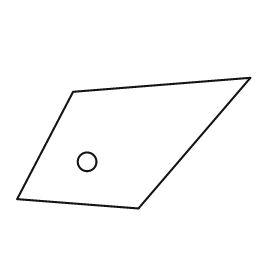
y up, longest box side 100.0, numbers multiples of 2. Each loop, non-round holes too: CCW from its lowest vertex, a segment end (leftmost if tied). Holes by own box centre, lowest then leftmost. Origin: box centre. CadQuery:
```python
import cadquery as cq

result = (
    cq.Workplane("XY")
    .moveTo(2.0, -28.0)
    .lineTo(50.0, 28.0)
    .lineTo(-26.0, 22.0)
    .lineTo(-50.0, -24.0)
    .close()
    .moveTo(-20.0, -8.0)
    .circle(4.0)
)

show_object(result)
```